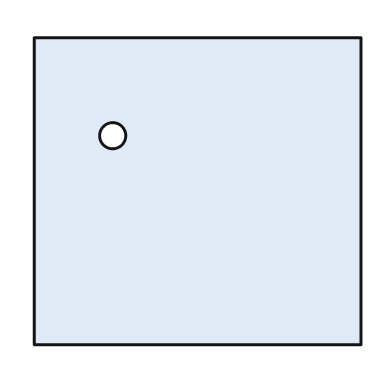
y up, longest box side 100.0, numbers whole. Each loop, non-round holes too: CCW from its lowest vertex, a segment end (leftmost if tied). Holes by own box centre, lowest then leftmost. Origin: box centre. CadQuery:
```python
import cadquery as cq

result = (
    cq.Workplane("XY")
    .moveTo(-50.0, -47.0)
    .lineTo(50.0, -47.0)
    .lineTo(50.0, 47.0)
    .lineTo(-50.0, 47.0)
    .close()
    .moveTo(-26.0, 17.0)
    .circle(4.0)
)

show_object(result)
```